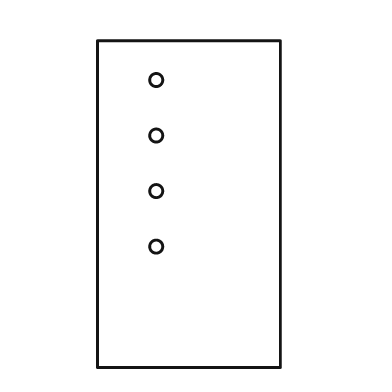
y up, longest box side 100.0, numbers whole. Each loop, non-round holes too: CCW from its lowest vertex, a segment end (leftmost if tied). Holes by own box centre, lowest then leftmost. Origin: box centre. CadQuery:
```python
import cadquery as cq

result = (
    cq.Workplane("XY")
    .moveTo(-28.0, -50.0)
    .lineTo(28.0, -50.0)
    .lineTo(28.0, 50.0)
    .lineTo(-28.0, 50.0)
    .close()
    .moveTo(-10.0, -13.0)
    .circle(2.0)
    .moveTo(-10.0, 4.0)
    .circle(2.0)
    .moveTo(-10.0, 21.0)
    .circle(2.0)
    .moveTo(-10.0, 38.0)
    .circle(2.0)
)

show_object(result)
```